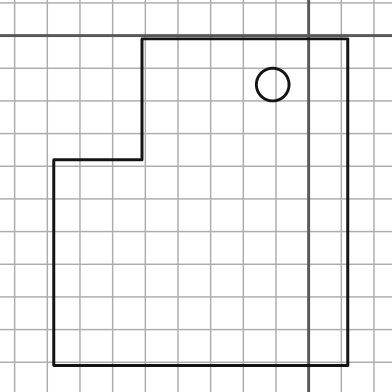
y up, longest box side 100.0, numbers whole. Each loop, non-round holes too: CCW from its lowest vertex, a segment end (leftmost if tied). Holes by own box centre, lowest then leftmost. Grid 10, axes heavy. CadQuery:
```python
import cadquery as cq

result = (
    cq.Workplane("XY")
    .moveTo(-78.0, -101.0)
    .lineTo(12.0, -101.0)
    .lineTo(12.0, -1.0)
    .lineTo(-51.0, -1.0)
    .lineTo(-51.0, -38.0)
    .lineTo(-78.0, -38.0)
    .close()
    .moveTo(-11.0, -15.0)
    .circle(5.0)
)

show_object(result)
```